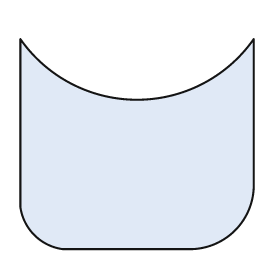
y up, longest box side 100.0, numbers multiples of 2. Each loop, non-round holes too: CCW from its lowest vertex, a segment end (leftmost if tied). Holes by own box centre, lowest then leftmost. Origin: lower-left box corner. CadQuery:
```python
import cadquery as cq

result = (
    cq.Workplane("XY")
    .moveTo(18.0, 0.0)
    .lineTo(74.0, 0.0)
    .threePointArc((92.0, 8.0), (100.0, 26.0))
    .lineTo(100.0, 90.0)
    .threePointArc((50.0, 64.0), (0.0, 90.0))
    .lineTo(0.0, 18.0)
    .threePointArc((6.0, 6.0), (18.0, 0.0))
    .close()
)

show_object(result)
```